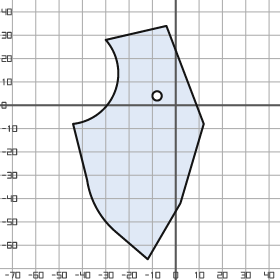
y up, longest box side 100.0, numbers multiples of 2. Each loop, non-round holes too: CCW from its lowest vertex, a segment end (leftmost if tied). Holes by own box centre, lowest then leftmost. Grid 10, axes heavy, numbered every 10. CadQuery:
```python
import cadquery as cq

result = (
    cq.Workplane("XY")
    .moveTo(-12.0, -66.0)
    .lineTo(2.0, -42.0)
    .lineTo(12.0, -8.0)
    .lineTo(-4.0, 34.0)
    .lineTo(-30.0, 28.0)
    .threePointArc((-26.0, 6.0), (-44.0, -8.0))
    .lineTo(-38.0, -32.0)
    .threePointArc((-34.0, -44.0), (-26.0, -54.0))
    .close()
    .moveTo(-8.0, 4.0)
    .circle(2.0)
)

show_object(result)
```